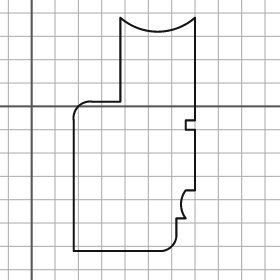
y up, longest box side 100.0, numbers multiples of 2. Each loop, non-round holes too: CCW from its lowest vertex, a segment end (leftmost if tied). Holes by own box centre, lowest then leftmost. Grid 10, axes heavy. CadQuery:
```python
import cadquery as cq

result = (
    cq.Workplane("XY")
    .moveTo(18.0, -62.0)
    .lineTo(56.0, -62.0)
    .threePointArc((60.0, -60.0), (62.0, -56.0))
    .lineTo(62.0, -48.0)
    .lineTo(66.0, -48.0)
    .threePointArc((64.0, -42.0), (66.0, -36.0))
    .lineTo(70.0, -36.0)
    .lineTo(70.0, -10.0)
    .lineTo(66.0, -10.0)
    .lineTo(66.0, -6.0)
    .lineTo(70.0, -6.0)
    .lineTo(70.0, 38.0)
    .threePointArc((54.0, 32.0), (38.0, 38.0))
    .lineTo(38.0, 2.0)
    .lineTo(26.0, 2.0)
    .threePointArc((20.0, 0.0), (18.0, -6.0))
    .close()
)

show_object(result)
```